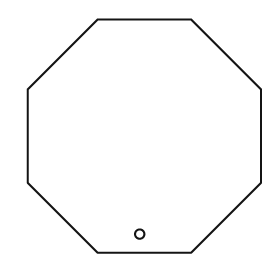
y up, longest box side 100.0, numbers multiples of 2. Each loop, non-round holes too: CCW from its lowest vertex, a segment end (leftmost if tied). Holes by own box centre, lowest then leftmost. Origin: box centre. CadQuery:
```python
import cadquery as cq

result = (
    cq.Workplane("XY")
    .moveTo(-20.0, -50.0)
    .lineTo(20.0, -50.0)
    .lineTo(50.0, -20.0)
    .lineTo(50.0, 20.0)
    .lineTo(20.0, 50.0)
    .lineTo(-20.0, 50.0)
    .lineTo(-50.0, 20.0)
    .lineTo(-50.0, -20.0)
    .close()
    .moveTo(-2.0, -42.0)
    .circle(2.0)
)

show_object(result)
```